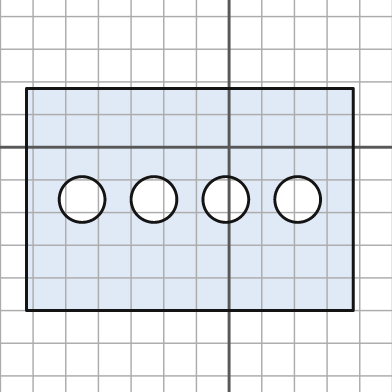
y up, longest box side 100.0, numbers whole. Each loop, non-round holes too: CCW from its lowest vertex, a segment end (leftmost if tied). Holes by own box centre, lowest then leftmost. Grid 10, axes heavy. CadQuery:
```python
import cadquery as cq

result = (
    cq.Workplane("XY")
    .moveTo(-62.0, -50.0)
    .lineTo(38.0, -50.0)
    .lineTo(38.0, 18.0)
    .lineTo(-62.0, 18.0)
    .close()
    .moveTo(-45.0, -16.0)
    .circle(7.0)
    .moveTo(-23.0, -16.0)
    .circle(7.0)
    .moveTo(-1.0, -16.0)
    .circle(7.0)
    .moveTo(21.0, -16.0)
    .circle(7.0)
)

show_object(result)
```